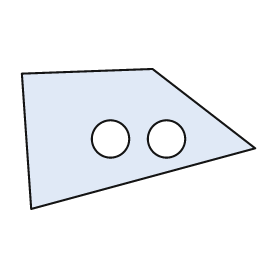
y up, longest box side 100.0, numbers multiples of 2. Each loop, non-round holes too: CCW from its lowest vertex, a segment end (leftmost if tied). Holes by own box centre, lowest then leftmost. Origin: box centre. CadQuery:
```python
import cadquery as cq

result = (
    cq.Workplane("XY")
    .moveTo(-46.0, -30.0)
    .lineTo(50.0, -4.0)
    .lineTo(6.0, 30.0)
    .lineTo(-50.0, 28.0)
    .close()
    .moveTo(-12.0, 0.0)
    .circle(8.0)
    .moveTo(12.0, 0.0)
    .circle(8.0)
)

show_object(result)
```